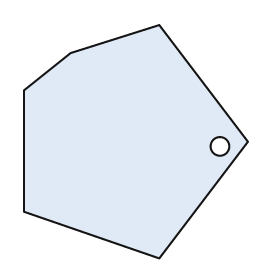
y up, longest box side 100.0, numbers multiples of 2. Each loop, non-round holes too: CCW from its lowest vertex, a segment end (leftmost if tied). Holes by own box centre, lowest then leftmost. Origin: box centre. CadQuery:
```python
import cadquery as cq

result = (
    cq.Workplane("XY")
    .moveTo(10.0, -50.0)
    .lineTo(48.0, 0.0)
    .lineTo(10.0, 50.0)
    .lineTo(-28.0, 38.0)
    .lineTo(-48.0, 22.0)
    .lineTo(-48.0, -30.0)
    .close()
    .moveTo(36.0, -2.0)
    .circle(4.0)
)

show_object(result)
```